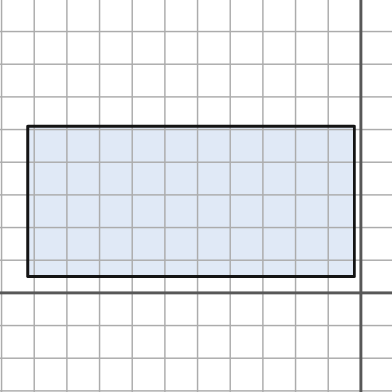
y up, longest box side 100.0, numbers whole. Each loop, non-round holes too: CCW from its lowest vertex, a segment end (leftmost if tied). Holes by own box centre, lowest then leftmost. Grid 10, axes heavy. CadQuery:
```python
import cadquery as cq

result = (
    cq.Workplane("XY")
    .moveTo(-102.0, 5.0)
    .lineTo(-2.0, 5.0)
    .lineTo(-2.0, 51.0)
    .lineTo(-102.0, 51.0)
    .close()
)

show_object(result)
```